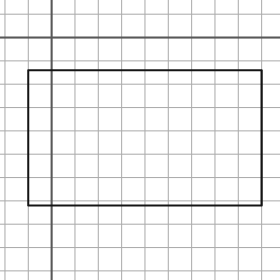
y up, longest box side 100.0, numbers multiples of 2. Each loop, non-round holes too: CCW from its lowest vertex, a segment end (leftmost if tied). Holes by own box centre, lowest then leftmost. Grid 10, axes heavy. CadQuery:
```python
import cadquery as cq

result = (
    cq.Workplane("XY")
    .moveTo(-10.0, -72.0)
    .lineTo(90.0, -72.0)
    .lineTo(90.0, -14.0)
    .lineTo(-10.0, -14.0)
    .close()
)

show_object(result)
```